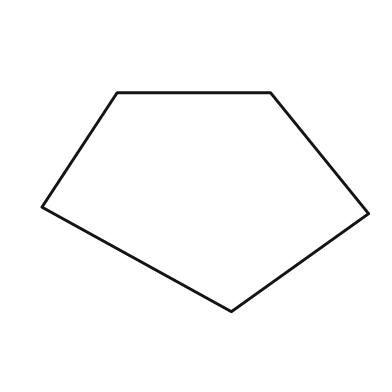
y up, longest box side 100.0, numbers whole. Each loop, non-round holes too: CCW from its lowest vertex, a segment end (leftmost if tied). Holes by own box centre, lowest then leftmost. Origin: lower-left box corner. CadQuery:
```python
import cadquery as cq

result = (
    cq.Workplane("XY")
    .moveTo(58.0, 0.0)
    .lineTo(100.0, 30.0)
    .lineTo(70.0, 67.0)
    .lineTo(23.0, 67.0)
    .lineTo(0.0, 32.0)
    .close()
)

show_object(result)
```